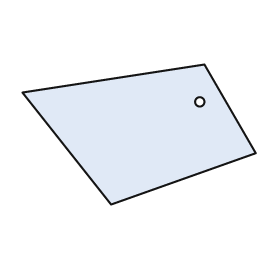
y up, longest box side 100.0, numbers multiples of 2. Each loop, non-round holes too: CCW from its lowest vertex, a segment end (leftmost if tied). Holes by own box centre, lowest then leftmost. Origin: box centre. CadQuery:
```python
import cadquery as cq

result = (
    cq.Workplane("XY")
    .moveTo(-12.0, -30.0)
    .lineTo(50.0, -8.0)
    .lineTo(28.0, 30.0)
    .lineTo(-50.0, 18.0)
    .close()
    .moveTo(26.0, 14.0)
    .circle(2.0)
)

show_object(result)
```